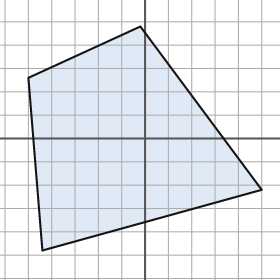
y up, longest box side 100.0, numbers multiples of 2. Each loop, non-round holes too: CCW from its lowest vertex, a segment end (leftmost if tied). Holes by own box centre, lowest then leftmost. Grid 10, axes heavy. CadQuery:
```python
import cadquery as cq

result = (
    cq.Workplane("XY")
    .moveTo(-44.0, -48.0)
    .lineTo(50.0, -22.0)
    .lineTo(-2.0, 48.0)
    .lineTo(-50.0, 26.0)
    .close()
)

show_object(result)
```